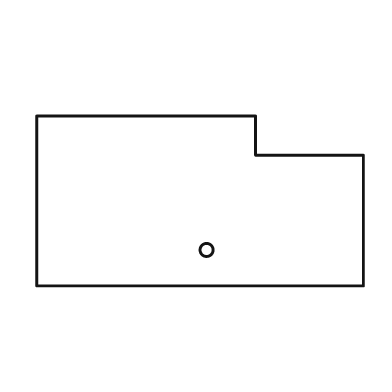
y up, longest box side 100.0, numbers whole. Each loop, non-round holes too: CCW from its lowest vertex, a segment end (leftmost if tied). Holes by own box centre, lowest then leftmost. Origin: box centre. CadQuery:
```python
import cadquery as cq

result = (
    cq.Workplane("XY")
    .moveTo(-50.0, -26.0)
    .lineTo(50.0, -26.0)
    .lineTo(50.0, 14.0)
    .lineTo(17.0, 14.0)
    .lineTo(17.0, 26.0)
    .lineTo(-50.0, 26.0)
    .close()
    .moveTo(2.0, -15.0)
    .circle(2.0)
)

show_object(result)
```